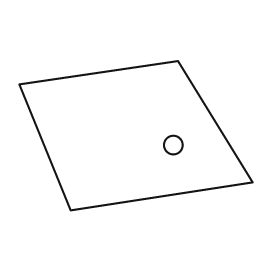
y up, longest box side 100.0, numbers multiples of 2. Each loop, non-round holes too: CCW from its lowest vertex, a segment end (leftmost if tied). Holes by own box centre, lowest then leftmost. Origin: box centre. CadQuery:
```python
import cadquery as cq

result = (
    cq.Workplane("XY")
    .moveTo(-28.0, -32.0)
    .lineTo(50.0, -20.0)
    .lineTo(18.0, 32.0)
    .lineTo(-50.0, 22.0)
    .close()
    .moveTo(16.0, -4.0)
    .circle(4.0)
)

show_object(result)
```